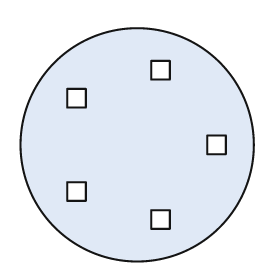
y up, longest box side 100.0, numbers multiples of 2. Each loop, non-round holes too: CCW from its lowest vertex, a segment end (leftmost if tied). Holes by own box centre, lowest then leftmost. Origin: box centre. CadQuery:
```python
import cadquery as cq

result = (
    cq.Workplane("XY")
    .moveTo(0.0, 0.0)
    .circle(50.0)
    .moveTo(6.0, -36.0)
    .lineTo(14.0, -36.0)
    .lineTo(14.0, -28.0)
    .lineTo(6.0, -28.0)
    .close()
    .moveTo(-30.0, -24.0)
    .lineTo(-22.0, -24.0)
    .lineTo(-22.0, -16.0)
    .lineTo(-30.0, -16.0)
    .close()
    .moveTo(30.0, -4.0)
    .lineTo(38.0, -4.0)
    .lineTo(38.0, 4.0)
    .lineTo(30.0, 4.0)
    .close()
    .moveTo(-30.0, 16.0)
    .lineTo(-22.0, 16.0)
    .lineTo(-22.0, 24.0)
    .lineTo(-30.0, 24.0)
    .close()
    .moveTo(6.0, 28.0)
    .lineTo(14.0, 28.0)
    .lineTo(14.0, 36.0)
    .lineTo(6.0, 36.0)
    .close()
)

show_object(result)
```